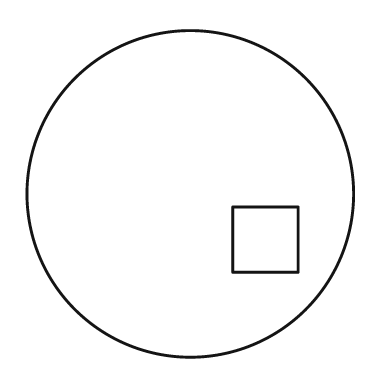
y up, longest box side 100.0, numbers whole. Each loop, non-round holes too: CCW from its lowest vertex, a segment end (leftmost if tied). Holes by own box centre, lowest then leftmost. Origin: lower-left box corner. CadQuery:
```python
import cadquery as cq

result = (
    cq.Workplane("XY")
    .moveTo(50.0, 50.0)
    .circle(50.0)
    .moveTo(63.0, 26.0)
    .lineTo(83.0, 26.0)
    .lineTo(83.0, 46.0)
    .lineTo(63.0, 46.0)
    .close()
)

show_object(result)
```